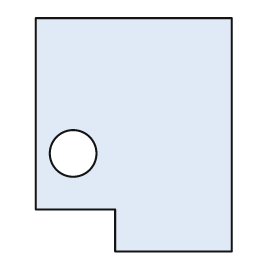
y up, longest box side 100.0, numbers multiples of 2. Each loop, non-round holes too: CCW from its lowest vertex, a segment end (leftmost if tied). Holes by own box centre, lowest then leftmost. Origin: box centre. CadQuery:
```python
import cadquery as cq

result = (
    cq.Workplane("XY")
    .moveTo(-8.0, -50.0)
    .lineTo(42.0, -50.0)
    .lineTo(42.0, 50.0)
    .lineTo(-42.0, 50.0)
    .lineTo(-42.0, -32.0)
    .lineTo(-8.0, -32.0)
    .close()
    .moveTo(-26.0, -8.0)
    .circle(10.0)
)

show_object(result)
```